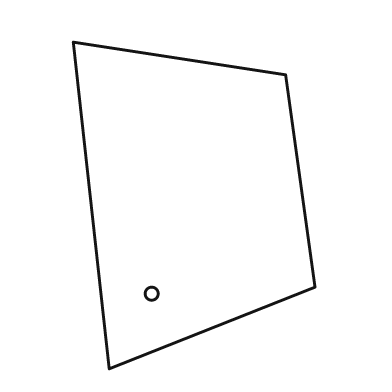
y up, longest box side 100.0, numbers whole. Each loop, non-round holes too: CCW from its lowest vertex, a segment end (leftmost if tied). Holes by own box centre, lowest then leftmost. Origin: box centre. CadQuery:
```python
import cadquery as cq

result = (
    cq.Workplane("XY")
    .moveTo(-26.0, -50.0)
    .lineTo(37.0, -25.0)
    .lineTo(28.0, 40.0)
    .lineTo(-37.0, 50.0)
    .close()
    .moveTo(-13.0, -27.0)
    .circle(2.0)
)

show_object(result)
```